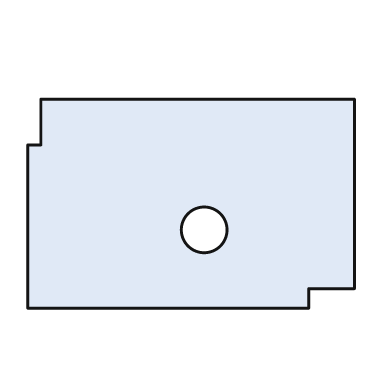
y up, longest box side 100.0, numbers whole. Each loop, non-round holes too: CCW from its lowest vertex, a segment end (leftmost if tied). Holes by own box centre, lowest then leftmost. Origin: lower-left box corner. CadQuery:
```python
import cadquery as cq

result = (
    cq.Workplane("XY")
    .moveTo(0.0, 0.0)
    .lineTo(86.0, 0.0)
    .lineTo(86.0, 6.0)
    .lineTo(100.0, 6.0)
    .lineTo(100.0, 64.0)
    .lineTo(4.0, 64.0)
    .lineTo(4.0, 50.0)
    .lineTo(0.0, 50.0)
    .close()
    .moveTo(54.0, 24.0)
    .circle(7.0)
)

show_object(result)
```